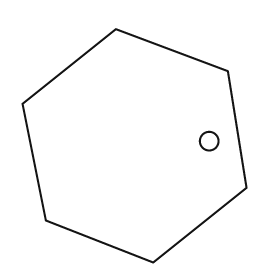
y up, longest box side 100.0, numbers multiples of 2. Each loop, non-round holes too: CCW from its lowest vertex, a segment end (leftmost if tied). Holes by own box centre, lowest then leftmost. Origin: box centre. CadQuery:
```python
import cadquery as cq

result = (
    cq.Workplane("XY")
    .moveTo(8.0, -50.0)
    .lineTo(48.0, -18.0)
    .lineTo(40.0, 32.0)
    .lineTo(-8.0, 50.0)
    .lineTo(-48.0, 18.0)
    .lineTo(-38.0, -32.0)
    .close()
    .moveTo(32.0, 2.0)
    .circle(4.0)
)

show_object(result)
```